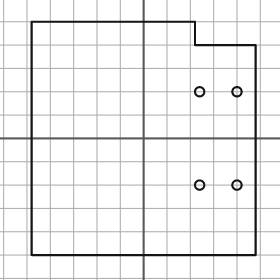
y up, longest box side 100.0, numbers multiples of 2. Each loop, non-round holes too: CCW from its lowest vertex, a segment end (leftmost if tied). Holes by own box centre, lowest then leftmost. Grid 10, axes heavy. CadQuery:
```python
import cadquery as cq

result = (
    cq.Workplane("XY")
    .moveTo(-48.0, -50.0)
    .lineTo(48.0, -50.0)
    .lineTo(48.0, 40.0)
    .lineTo(22.0, 40.0)
    .lineTo(22.0, 50.0)
    .lineTo(-48.0, 50.0)
    .close()
    .moveTo(24.0, -20.0)
    .circle(2.0)
    .moveTo(40.0, -20.0)
    .circle(2.0)
    .moveTo(24.0, 20.0)
    .circle(2.0)
    .moveTo(40.0, 20.0)
    .circle(2.0)
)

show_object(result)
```